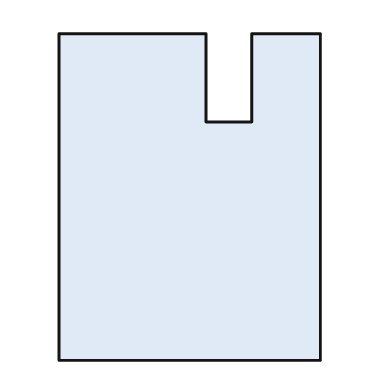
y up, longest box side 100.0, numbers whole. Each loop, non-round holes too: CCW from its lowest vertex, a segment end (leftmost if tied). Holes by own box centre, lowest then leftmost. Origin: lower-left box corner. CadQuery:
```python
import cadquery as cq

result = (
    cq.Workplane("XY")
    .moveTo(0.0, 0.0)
    .lineTo(80.0, 0.0)
    .lineTo(80.0, 100.0)
    .lineTo(59.0, 100.0)
    .lineTo(59.0, 73.0)
    .lineTo(45.0, 73.0)
    .lineTo(45.0, 100.0)
    .lineTo(0.0, 100.0)
    .close()
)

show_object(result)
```